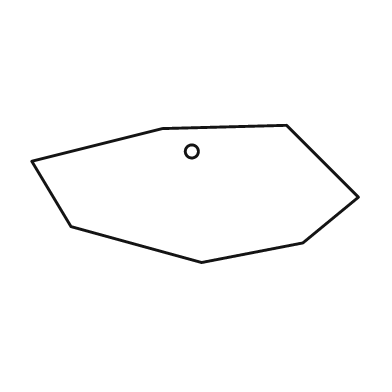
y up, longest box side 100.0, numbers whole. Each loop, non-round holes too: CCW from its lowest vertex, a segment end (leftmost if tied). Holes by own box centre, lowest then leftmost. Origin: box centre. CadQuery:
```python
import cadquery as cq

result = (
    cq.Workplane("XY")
    .moveTo(2.0, -21.0)
    .lineTo(33.0, -15.0)
    .lineTo(50.0, -1.0)
    .lineTo(28.0, 21.0)
    .lineTo(-10.0, 20.0)
    .lineTo(-50.0, 10.0)
    .lineTo(-38.0, -10.0)
    .close()
    .moveTo(-1.0, 13.0)
    .circle(2.0)
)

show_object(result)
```